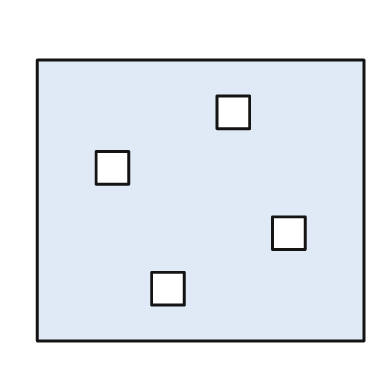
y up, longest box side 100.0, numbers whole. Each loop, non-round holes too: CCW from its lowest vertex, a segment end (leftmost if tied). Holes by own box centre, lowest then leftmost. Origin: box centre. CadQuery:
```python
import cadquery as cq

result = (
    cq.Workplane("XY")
    .moveTo(-50.0, -43.0)
    .lineTo(50.0, -43.0)
    .lineTo(50.0, 43.0)
    .lineTo(-50.0, 43.0)
    .close()
    .moveTo(-15.0, -32.0)
    .lineTo(-5.0, -32.0)
    .lineTo(-5.0, -22.0)
    .lineTo(-15.0, -22.0)
    .close()
    .moveTo(22.0, -15.0)
    .lineTo(32.0, -15.0)
    .lineTo(32.0, -5.0)
    .lineTo(22.0, -5.0)
    .close()
    .moveTo(-32.0, 5.0)
    .lineTo(-22.0, 5.0)
    .lineTo(-22.0, 15.0)
    .lineTo(-32.0, 15.0)
    .close()
    .moveTo(5.0, 22.0)
    .lineTo(15.0, 22.0)
    .lineTo(15.0, 32.0)
    .lineTo(5.0, 32.0)
    .close()
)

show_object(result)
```